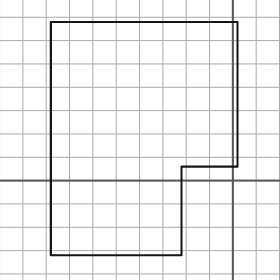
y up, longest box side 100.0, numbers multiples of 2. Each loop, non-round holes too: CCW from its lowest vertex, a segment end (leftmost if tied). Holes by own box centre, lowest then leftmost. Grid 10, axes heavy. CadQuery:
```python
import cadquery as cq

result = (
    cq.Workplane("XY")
    .moveTo(-78.0, -32.0)
    .lineTo(-22.0, -32.0)
    .lineTo(-22.0, 6.0)
    .lineTo(2.0, 6.0)
    .lineTo(2.0, 68.0)
    .lineTo(-78.0, 68.0)
    .close()
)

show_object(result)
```